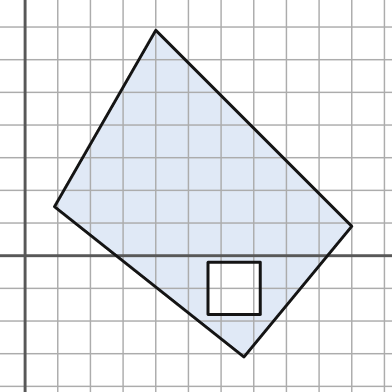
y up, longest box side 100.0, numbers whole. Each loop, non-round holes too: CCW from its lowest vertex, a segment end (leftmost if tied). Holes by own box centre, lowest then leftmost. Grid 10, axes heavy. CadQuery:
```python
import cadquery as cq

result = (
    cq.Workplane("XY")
    .moveTo(67.0, -31.0)
    .lineTo(100.0, 9.0)
    .lineTo(40.0, 69.0)
    .lineTo(9.0, 15.0)
    .close()
    .moveTo(56.0, -18.0)
    .lineTo(72.0, -18.0)
    .lineTo(72.0, -2.0)
    .lineTo(56.0, -2.0)
    .close()
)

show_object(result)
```